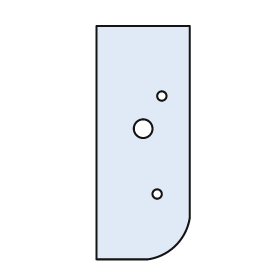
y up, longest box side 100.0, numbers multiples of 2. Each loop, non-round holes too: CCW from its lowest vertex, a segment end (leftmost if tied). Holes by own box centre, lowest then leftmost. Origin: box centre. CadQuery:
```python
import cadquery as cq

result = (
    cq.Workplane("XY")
    .moveTo(-20.0, -50.0)
    .lineTo(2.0, -50.0)
    .threePointArc((14.0, -44.0), (20.0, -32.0))
    .lineTo(20.0, 50.0)
    .lineTo(-20.0, 50.0)
    .close()
    .moveTo(6.0, -22.0)
    .circle(2.0)
    .moveTo(0.0, 6.0)
    .circle(4.0)
    .moveTo(8.0, 20.0)
    .circle(2.0)
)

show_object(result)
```